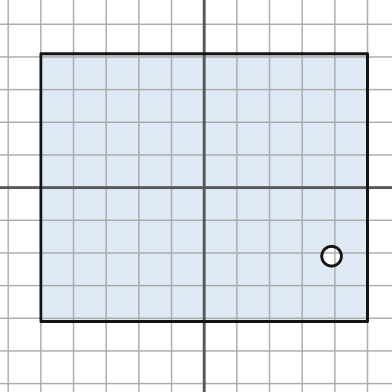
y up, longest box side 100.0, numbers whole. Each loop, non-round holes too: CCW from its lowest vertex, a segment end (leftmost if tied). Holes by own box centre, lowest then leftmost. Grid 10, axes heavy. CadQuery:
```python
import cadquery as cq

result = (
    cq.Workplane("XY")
    .moveTo(-50.0, -41.0)
    .lineTo(50.0, -41.0)
    .lineTo(50.0, 41.0)
    .lineTo(-50.0, 41.0)
    .close()
    .moveTo(39.0, -21.0)
    .circle(3.0)
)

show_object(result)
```